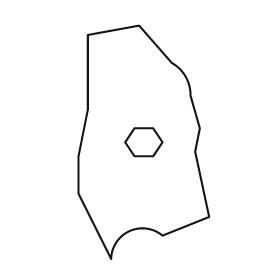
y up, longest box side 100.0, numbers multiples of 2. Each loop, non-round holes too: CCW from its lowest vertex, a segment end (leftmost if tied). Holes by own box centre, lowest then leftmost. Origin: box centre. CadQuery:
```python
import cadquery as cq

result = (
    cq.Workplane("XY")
    .moveTo(-14.0, -50.0)
    .threePointArc((-6.0, -38.0), (8.0, -40.0))
    .lineTo(28.0, -32.0)
    .lineTo(22.0, -4.0)
    .lineTo(24.0, 6.0)
    .lineTo(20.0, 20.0)
    .threePointArc((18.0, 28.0), (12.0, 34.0))
    .lineTo(-2.0, 50.0)
    .lineTo(-24.0, 46.0)
    .lineTo(-24.0, 14.0)
    .lineTo(-28.0, -6.0)
    .lineTo(-28.0, -22.0)
    .close()
    .moveTo(-4.0, -6.0)
    .lineTo(4.0, -6.0)
    .lineTo(8.0, 0.0)
    .lineTo(4.0, 6.0)
    .lineTo(-4.0, 6.0)
    .lineTo(-8.0, 0.0)
    .close()
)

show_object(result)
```